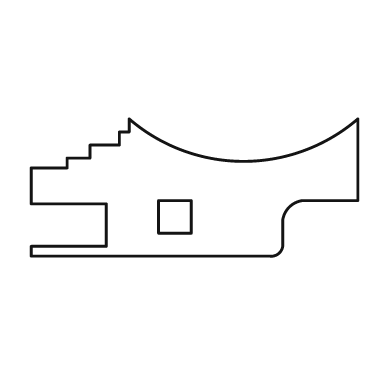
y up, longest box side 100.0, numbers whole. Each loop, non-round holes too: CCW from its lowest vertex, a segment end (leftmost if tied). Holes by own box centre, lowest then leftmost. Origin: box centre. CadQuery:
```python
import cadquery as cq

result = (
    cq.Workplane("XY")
    .moveTo(-50.0, -21.0)
    .lineTo(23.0, -21.0)
    .threePointArc((26.0, -20.0), (27.0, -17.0))
    .lineTo(27.0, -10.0)
    .threePointArc((29.0, -6.0), (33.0, -4.0))
    .lineTo(50.0, -4.0)
    .lineTo(50.0, 21.0)
    .threePointArc((15.0, 8.0), (-20.0, 21.0))
    .lineTo(-20.0, 17.0)
    .lineTo(-23.0, 17.0)
    .lineTo(-23.0, 13.0)
    .lineTo(-32.0, 13.0)
    .lineTo(-32.0, 9.0)
    .lineTo(-39.0, 9.0)
    .lineTo(-39.0, 6.0)
    .lineTo(-50.0, 6.0)
    .lineTo(-50.0, -5.0)
    .lineTo(-27.0, -5.0)
    .lineTo(-27.0, -18.0)
    .lineTo(-50.0, -18.0)
    .close()
    .moveTo(-11.0, -14.0)
    .lineTo(-1.0, -14.0)
    .lineTo(-1.0, -4.0)
    .lineTo(-11.0, -4.0)
    .close()
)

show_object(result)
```